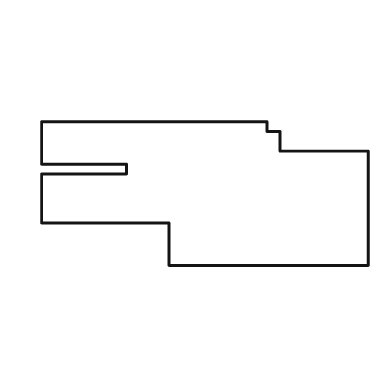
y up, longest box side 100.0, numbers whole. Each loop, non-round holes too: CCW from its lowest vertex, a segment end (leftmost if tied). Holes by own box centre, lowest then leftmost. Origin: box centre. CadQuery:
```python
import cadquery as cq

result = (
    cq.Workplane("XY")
    .moveTo(-11.0, -22.0)
    .lineTo(50.0, -22.0)
    .lineTo(50.0, 13.0)
    .lineTo(23.0, 13.0)
    .lineTo(23.0, 19.0)
    .lineTo(19.0, 19.0)
    .lineTo(19.0, 22.0)
    .lineTo(-50.0, 22.0)
    .lineTo(-50.0, 9.0)
    .lineTo(-24.0, 9.0)
    .lineTo(-24.0, 6.0)
    .lineTo(-50.0, 6.0)
    .lineTo(-50.0, -9.0)
    .lineTo(-11.0, -9.0)
    .close()
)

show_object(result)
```